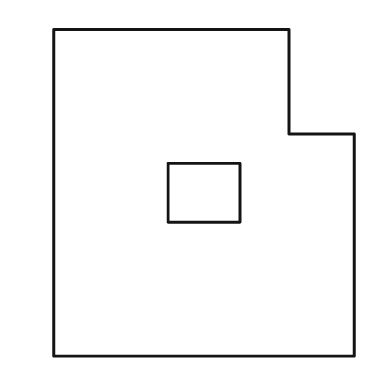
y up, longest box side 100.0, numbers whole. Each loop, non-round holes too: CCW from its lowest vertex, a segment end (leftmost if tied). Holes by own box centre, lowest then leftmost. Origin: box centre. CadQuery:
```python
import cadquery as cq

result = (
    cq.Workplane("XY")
    .moveTo(-46.0, -50.0)
    .lineTo(46.0, -50.0)
    .lineTo(46.0, 18.0)
    .lineTo(26.0, 18.0)
    .lineTo(26.0, 50.0)
    .lineTo(-46.0, 50.0)
    .close()
    .moveTo(-11.0, -9.0)
    .lineTo(11.0, -9.0)
    .lineTo(11.0, 9.0)
    .lineTo(-11.0, 9.0)
    .close()
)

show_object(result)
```